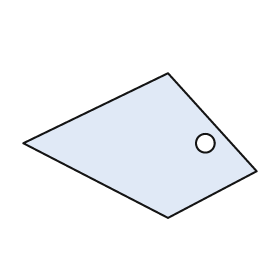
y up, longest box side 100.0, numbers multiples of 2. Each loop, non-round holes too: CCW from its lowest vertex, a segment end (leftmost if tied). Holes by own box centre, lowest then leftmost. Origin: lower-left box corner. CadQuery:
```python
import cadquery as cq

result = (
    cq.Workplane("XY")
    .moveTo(62.0, 0.0)
    .lineTo(100.0, 20.0)
    .lineTo(62.0, 62.0)
    .lineTo(0.0, 32.0)
    .close()
    .moveTo(78.0, 32.0)
    .circle(4.0)
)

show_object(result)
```